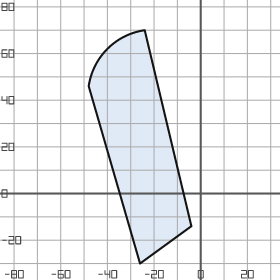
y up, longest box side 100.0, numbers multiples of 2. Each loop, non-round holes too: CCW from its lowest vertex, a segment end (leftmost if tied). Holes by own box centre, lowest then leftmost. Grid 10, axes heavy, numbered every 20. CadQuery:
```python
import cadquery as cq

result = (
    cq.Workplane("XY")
    .moveTo(-26.0, -30.0)
    .lineTo(-4.0, -14.0)
    .lineTo(-24.0, 70.0)
    .threePointArc((-40.0, 62.0), (-48.0, 46.0))
    .close()
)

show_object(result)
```